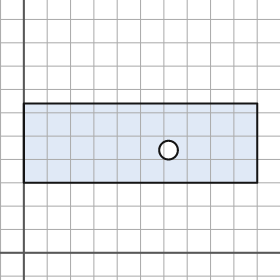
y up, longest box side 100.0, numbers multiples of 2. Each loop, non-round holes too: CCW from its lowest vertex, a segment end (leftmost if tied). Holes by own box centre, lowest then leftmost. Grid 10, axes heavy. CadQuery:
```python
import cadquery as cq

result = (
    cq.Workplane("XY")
    .moveTo(0.0, 30.0)
    .lineTo(100.0, 30.0)
    .lineTo(100.0, 64.0)
    .lineTo(0.0, 64.0)
    .close()
    .moveTo(62.0, 44.0)
    .circle(4.0)
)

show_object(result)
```